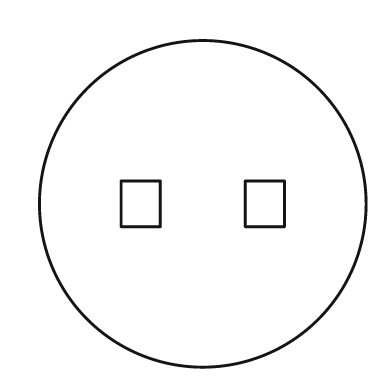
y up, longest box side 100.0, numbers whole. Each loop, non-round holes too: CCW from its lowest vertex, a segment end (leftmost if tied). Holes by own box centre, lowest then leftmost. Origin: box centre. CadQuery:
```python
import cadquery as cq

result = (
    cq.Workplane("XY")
    .moveTo(0.0, 0.0)
    .circle(50.0)
    .moveTo(-25.0, -7.0)
    .lineTo(-13.0, -7.0)
    .lineTo(-13.0, 7.0)
    .lineTo(-25.0, 7.0)
    .close()
    .moveTo(13.0, -7.0)
    .lineTo(25.0, -7.0)
    .lineTo(25.0, 7.0)
    .lineTo(13.0, 7.0)
    .close()
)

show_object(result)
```